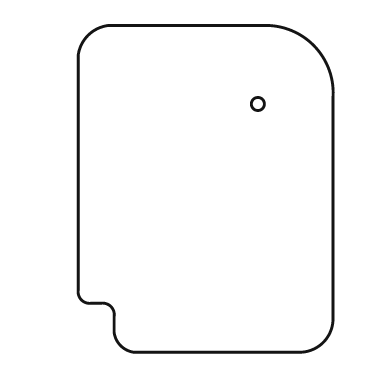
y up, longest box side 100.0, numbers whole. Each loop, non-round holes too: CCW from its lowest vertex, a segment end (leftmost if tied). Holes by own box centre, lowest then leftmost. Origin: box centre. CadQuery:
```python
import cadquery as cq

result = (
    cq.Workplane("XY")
    .moveTo(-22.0, -50.0)
    .lineTo(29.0, -50.0)
    .threePointArc((36.0, -47.0), (39.0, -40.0))
    .lineTo(39.0, 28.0)
    .threePointArc((33.0, 44.0), (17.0, 50.0))
    .lineTo(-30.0, 50.0)
    .threePointArc((-36.0, 47.0), (-39.0, 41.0))
    .lineTo(-39.0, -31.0)
    .threePointArc((-38.0, -34.0), (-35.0, -35.0))
    .lineTo(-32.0, -35.0)
    .threePointArc((-29.0, -36.0), (-28.0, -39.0))
    .lineTo(-28.0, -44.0)
    .threePointArc((-26.0, -48.0), (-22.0, -50.0))
    .close()
    .moveTo(16.0, 26.0)
    .circle(2.0)
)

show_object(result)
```